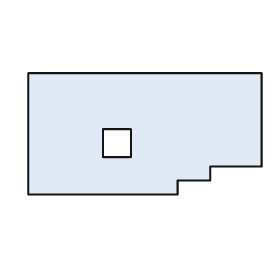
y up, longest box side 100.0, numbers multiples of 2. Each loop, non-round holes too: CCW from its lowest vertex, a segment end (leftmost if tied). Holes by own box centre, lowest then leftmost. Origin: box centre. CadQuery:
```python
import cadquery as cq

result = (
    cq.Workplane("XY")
    .moveTo(-50.0, -26.0)
    .lineTo(14.0, -26.0)
    .lineTo(14.0, -20.0)
    .lineTo(28.0, -20.0)
    .lineTo(28.0, -14.0)
    .lineTo(50.0, -14.0)
    .lineTo(50.0, 26.0)
    .lineTo(-50.0, 26.0)
    .close()
    .moveTo(-18.0, -10.0)
    .lineTo(-6.0, -10.0)
    .lineTo(-6.0, 2.0)
    .lineTo(-18.0, 2.0)
    .close()
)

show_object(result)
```